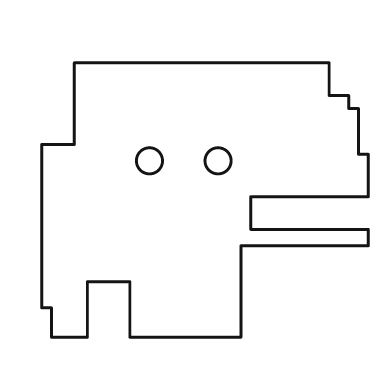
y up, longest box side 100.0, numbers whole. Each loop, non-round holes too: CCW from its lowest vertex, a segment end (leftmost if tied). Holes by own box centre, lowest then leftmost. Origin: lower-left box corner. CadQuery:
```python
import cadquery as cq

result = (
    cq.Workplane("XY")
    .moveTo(3.0, 0.0)
    .lineTo(14.0, 0.0)
    .lineTo(14.0, 17.0)
    .lineTo(27.0, 17.0)
    .lineTo(27.0, 0.0)
    .lineTo(61.0, 0.0)
    .lineTo(61.0, 28.0)
    .lineTo(100.0, 28.0)
    .lineTo(100.0, 33.0)
    .lineTo(64.0, 33.0)
    .lineTo(64.0, 43.0)
    .lineTo(100.0, 43.0)
    .lineTo(100.0, 56.0)
    .lineTo(97.0, 56.0)
    .lineTo(97.0, 70.0)
    .lineTo(94.0, 70.0)
    .lineTo(94.0, 74.0)
    .lineTo(88.0, 74.0)
    .lineTo(88.0, 84.0)
    .lineTo(10.0, 84.0)
    .lineTo(10.0, 59.0)
    .lineTo(0.0, 59.0)
    .lineTo(0.0, 9.0)
    .lineTo(3.0, 9.0)
    .close()
    .moveTo(33.0, 54.0)
    .circle(4.0)
    .moveTo(54.0, 54.0)
    .circle(4.0)
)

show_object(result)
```